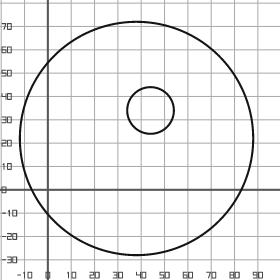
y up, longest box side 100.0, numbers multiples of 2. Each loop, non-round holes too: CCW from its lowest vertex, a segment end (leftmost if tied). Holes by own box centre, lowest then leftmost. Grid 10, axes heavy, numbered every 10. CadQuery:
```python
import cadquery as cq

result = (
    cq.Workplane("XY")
    .moveTo(38.0, 22.0)
    .circle(50.0)
    .moveTo(44.0, 34.0)
    .circle(10.0)
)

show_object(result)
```